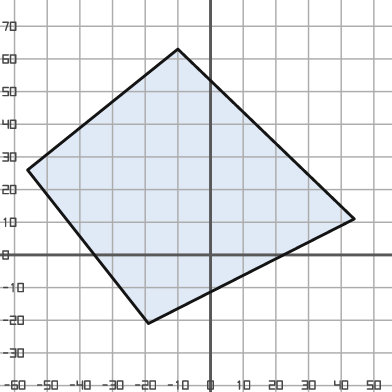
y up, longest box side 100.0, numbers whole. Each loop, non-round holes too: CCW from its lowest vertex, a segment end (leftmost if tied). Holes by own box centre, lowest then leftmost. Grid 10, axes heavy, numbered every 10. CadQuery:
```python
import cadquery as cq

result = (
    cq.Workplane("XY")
    .moveTo(-19.0, -21.0)
    .lineTo(44.0, 11.0)
    .lineTo(-10.0, 63.0)
    .lineTo(-56.0, 26.0)
    .close()
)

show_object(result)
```